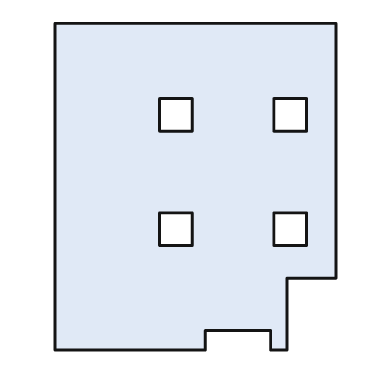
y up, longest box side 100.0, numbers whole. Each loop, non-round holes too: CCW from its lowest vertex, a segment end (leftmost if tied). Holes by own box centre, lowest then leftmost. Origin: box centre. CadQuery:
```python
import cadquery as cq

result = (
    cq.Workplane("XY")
    .moveTo(-43.0, -50.0)
    .lineTo(3.0, -50.0)
    .lineTo(3.0, -44.0)
    .lineTo(23.0, -44.0)
    .lineTo(23.0, -50.0)
    .lineTo(28.0, -50.0)
    .lineTo(28.0, -28.0)
    .lineTo(43.0, -28.0)
    .lineTo(43.0, 50.0)
    .lineTo(-43.0, 50.0)
    .close()
    .moveTo(-11.0, -18.0)
    .lineTo(-1.0, -18.0)
    .lineTo(-1.0, -8.0)
    .lineTo(-11.0, -8.0)
    .close()
    .moveTo(24.0, -18.0)
    .lineTo(34.0, -18.0)
    .lineTo(34.0, -8.0)
    .lineTo(24.0, -8.0)
    .close()
    .moveTo(-11.0, 17.0)
    .lineTo(-1.0, 17.0)
    .lineTo(-1.0, 27.0)
    .lineTo(-11.0, 27.0)
    .close()
    .moveTo(24.0, 17.0)
    .lineTo(34.0, 17.0)
    .lineTo(34.0, 27.0)
    .lineTo(24.0, 27.0)
    .close()
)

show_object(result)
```